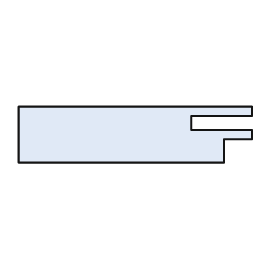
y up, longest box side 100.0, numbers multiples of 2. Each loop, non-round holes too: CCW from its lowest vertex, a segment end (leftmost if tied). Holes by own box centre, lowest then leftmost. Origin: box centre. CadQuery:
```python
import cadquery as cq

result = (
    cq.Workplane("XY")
    .moveTo(-50.0, -12.0)
    .lineTo(38.0, -12.0)
    .lineTo(38.0, -2.0)
    .lineTo(50.0, -2.0)
    .lineTo(50.0, 2.0)
    .lineTo(24.0, 2.0)
    .lineTo(24.0, 8.0)
    .lineTo(50.0, 8.0)
    .lineTo(50.0, 12.0)
    .lineTo(-50.0, 12.0)
    .close()
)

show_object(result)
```